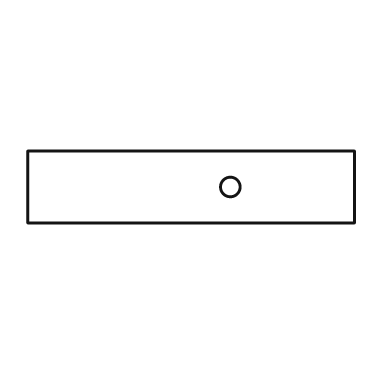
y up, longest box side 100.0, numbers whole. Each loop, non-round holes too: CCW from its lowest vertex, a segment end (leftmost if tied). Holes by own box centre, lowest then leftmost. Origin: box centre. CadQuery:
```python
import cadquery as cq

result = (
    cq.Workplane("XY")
    .moveTo(-50.0, -11.0)
    .lineTo(50.0, -11.0)
    .lineTo(50.0, 11.0)
    .lineTo(-50.0, 11.0)
    .close()
    .moveTo(12.0, 0.0)
    .circle(3.0)
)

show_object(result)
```